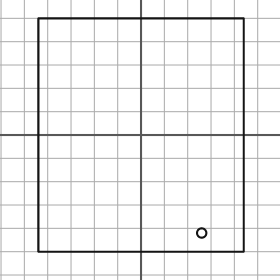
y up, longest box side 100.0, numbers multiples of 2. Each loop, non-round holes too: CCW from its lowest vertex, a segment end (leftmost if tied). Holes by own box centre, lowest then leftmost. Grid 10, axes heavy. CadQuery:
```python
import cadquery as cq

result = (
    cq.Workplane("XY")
    .moveTo(-44.0, -50.0)
    .lineTo(44.0, -50.0)
    .lineTo(44.0, 50.0)
    .lineTo(-44.0, 50.0)
    .close()
    .moveTo(26.0, -42.0)
    .circle(2.0)
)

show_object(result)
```